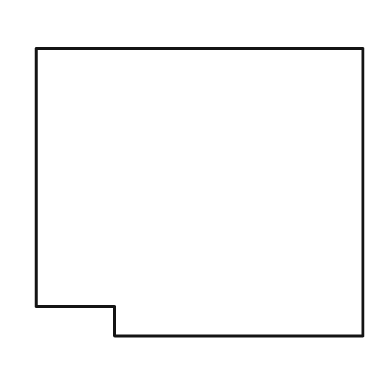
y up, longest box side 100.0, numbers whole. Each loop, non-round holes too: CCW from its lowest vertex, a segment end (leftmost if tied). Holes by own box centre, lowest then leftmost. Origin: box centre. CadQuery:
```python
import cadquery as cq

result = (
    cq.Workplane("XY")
    .moveTo(-26.0, -44.0)
    .lineTo(50.0, -44.0)
    .lineTo(50.0, 44.0)
    .lineTo(-50.0, 44.0)
    .lineTo(-50.0, -35.0)
    .lineTo(-26.0, -35.0)
    .close()
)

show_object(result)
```